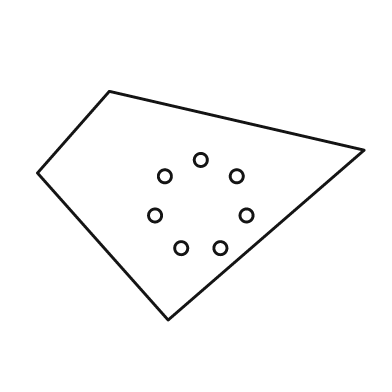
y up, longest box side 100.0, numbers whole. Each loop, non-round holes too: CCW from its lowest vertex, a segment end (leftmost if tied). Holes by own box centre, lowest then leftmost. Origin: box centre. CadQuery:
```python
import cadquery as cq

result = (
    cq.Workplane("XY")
    .moveTo(-10.0, -35.0)
    .lineTo(50.0, 17.0)
    .lineTo(-28.0, 35.0)
    .lineTo(-50.0, 10.0)
    .close()
    .moveTo(-6.0, -13.0)
    .circle(2.0)
    .moveTo(6.0, -13.0)
    .circle(2.0)
    .moveTo(-14.0, -3.0)
    .circle(2.0)
    .moveTo(14.0, -3.0)
    .circle(2.0)
    .moveTo(-11.0, 9.0)
    .circle(2.0)
    .moveTo(11.0, 9.0)
    .circle(2.0)
    .moveTo(0.0, 14.0)
    .circle(2.0)
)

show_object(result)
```